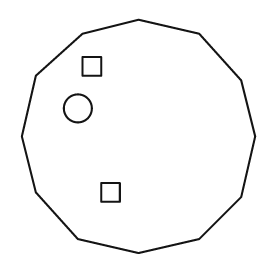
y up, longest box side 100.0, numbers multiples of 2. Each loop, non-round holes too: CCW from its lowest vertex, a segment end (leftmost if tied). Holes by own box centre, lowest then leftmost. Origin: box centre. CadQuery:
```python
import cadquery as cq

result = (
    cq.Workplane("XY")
    .moveTo(0.0, -50.0)
    .lineTo(26.0, -44.0)
    .lineTo(44.0, -26.0)
    .lineTo(50.0, 0.0)
    .lineTo(44.0, 24.0)
    .lineTo(26.0, 44.0)
    .lineTo(0.0, 50.0)
    .lineTo(-24.0, 44.0)
    .lineTo(-44.0, 26.0)
    .lineTo(-50.0, 0.0)
    .lineTo(-44.0, -24.0)
    .lineTo(-26.0, -44.0)
    .close()
    .moveTo(-16.0, -28.0)
    .lineTo(-8.0, -28.0)
    .lineTo(-8.0, -20.0)
    .lineTo(-16.0, -20.0)
    .close()
    .moveTo(-26.0, 12.0)
    .circle(6.0)
    .moveTo(-24.0, 26.0)
    .lineTo(-16.0, 26.0)
    .lineTo(-16.0, 34.0)
    .lineTo(-24.0, 34.0)
    .close()
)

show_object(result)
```